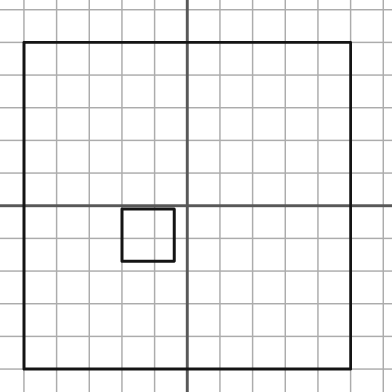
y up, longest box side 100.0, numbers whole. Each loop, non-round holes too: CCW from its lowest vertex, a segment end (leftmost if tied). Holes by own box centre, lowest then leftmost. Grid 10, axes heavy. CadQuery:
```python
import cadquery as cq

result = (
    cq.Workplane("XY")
    .moveTo(-50.0, -50.0)
    .lineTo(50.0, -50.0)
    .lineTo(50.0, 50.0)
    .lineTo(-50.0, 50.0)
    .close()
    .moveTo(-20.0, -17.0)
    .lineTo(-4.0, -17.0)
    .lineTo(-4.0, -1.0)
    .lineTo(-20.0, -1.0)
    .close()
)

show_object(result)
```